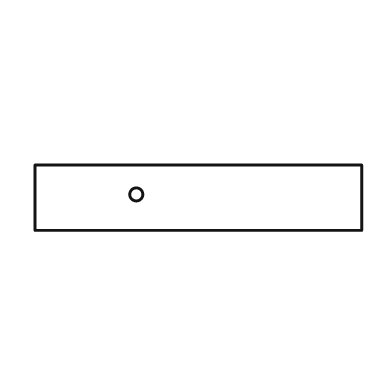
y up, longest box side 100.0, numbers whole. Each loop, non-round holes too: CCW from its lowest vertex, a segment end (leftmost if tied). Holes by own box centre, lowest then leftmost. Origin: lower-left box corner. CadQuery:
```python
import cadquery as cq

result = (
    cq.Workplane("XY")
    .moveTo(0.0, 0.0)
    .lineTo(100.0, 0.0)
    .lineTo(100.0, 20.0)
    .lineTo(0.0, 20.0)
    .close()
    .moveTo(31.0, 11.0)
    .circle(2.0)
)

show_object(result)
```